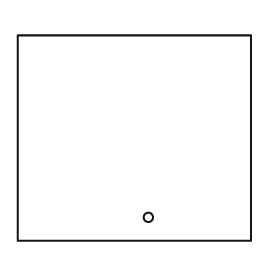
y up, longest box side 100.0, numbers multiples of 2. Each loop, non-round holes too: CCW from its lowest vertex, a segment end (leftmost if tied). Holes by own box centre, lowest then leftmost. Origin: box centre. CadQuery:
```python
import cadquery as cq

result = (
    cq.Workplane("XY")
    .moveTo(-50.0, -44.0)
    .lineTo(50.0, -44.0)
    .lineTo(50.0, 44.0)
    .lineTo(-50.0, 44.0)
    .close()
    .moveTo(6.0, -34.0)
    .circle(2.0)
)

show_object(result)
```